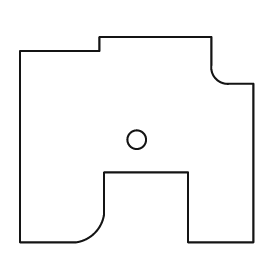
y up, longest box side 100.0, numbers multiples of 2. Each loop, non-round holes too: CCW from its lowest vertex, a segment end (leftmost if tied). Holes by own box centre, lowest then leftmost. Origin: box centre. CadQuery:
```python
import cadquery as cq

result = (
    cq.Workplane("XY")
    .moveTo(-50.0, -44.0)
    .lineTo(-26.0, -44.0)
    .threePointArc((-18.0, -40.0), (-14.0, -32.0))
    .lineTo(-14.0, -14.0)
    .lineTo(22.0, -14.0)
    .lineTo(22.0, -44.0)
    .lineTo(50.0, -44.0)
    .lineTo(50.0, 24.0)
    .lineTo(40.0, 24.0)
    .threePointArc((34.0, 26.0), (32.0, 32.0))
    .lineTo(32.0, 44.0)
    .lineTo(-16.0, 44.0)
    .lineTo(-16.0, 38.0)
    .lineTo(-50.0, 38.0)
    .close()
    .moveTo(0.0, 0.0)
    .circle(4.0)
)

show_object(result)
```